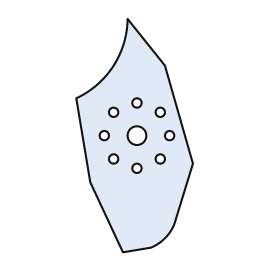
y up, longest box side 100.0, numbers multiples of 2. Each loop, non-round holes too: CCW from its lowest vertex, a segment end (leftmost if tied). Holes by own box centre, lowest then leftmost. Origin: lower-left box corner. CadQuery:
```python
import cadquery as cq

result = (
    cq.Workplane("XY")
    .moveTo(20.0, 0.0)
    .lineTo(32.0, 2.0)
    .threePointArc((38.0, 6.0), (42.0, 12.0))
    .lineTo(50.0, 38.0)
    .lineTo(38.0, 80.0)
    .lineTo(22.0, 100.0)
    .threePointArc((16.0, 80.0), (0.0, 66.0))
    .lineTo(6.0, 30.0)
    .close()
    .moveTo(26.0, 36.0)
    .circle(2.0)
    .moveTo(16.0, 40.0)
    .circle(2.0)
    .moveTo(36.0, 40.0)
    .circle(2.0)
    .moveTo(12.0, 50.0)
    .circle(2.0)
    .moveTo(26.0, 50.0)
    .circle(4.0)
    .moveTo(40.0, 50.0)
    .circle(2.0)
    .moveTo(16.0, 60.0)
    .circle(2.0)
    .moveTo(36.0, 60.0)
    .circle(2.0)
    .moveTo(26.0, 64.0)
    .circle(2.0)
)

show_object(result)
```